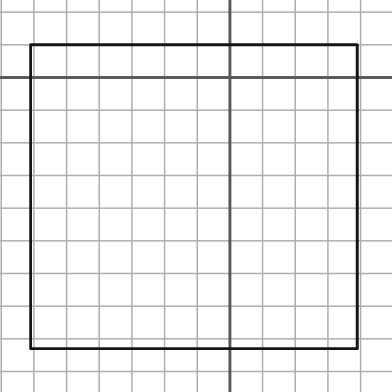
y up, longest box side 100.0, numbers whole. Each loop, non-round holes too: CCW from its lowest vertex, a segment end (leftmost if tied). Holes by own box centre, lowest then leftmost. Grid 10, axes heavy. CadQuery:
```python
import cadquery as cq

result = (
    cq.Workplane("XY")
    .moveTo(-61.0, -83.0)
    .lineTo(39.0, -83.0)
    .lineTo(39.0, 10.0)
    .lineTo(-61.0, 10.0)
    .close()
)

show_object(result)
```